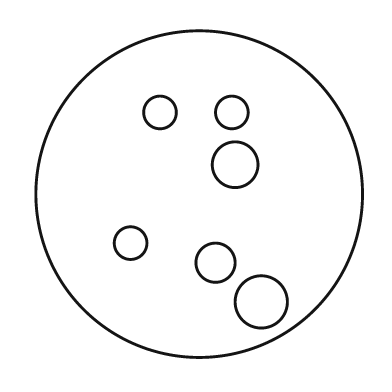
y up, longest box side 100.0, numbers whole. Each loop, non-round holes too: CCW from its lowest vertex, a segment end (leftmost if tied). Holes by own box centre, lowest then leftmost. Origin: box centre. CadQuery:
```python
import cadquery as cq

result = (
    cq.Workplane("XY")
    .moveTo(0.0, 0.0)
    .circle(50.0)
    .moveTo(19.0, -33.0)
    .circle(8.0)
    .moveTo(5.0, -21.0)
    .circle(6.0)
    .moveTo(-21.0, -15.0)
    .circle(5.0)
    .moveTo(11.0, 9.0)
    .circle(7.0)
    .moveTo(-12.0, 25.0)
    .circle(5.0)
    .moveTo(10.0, 25.0)
    .circle(5.0)
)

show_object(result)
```